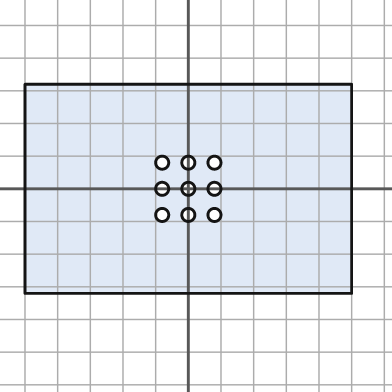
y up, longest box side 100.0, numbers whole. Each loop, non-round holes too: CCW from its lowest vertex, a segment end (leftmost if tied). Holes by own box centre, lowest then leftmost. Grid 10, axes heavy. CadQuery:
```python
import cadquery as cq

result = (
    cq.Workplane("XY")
    .moveTo(-50.0, -32.0)
    .lineTo(50.0, -32.0)
    .lineTo(50.0, 32.0)
    .lineTo(-50.0, 32.0)
    .close()
    .moveTo(-8.0, -8.0)
    .circle(2.0)
    .moveTo(0.0, -8.0)
    .circle(2.0)
    .moveTo(8.0, -8.0)
    .circle(2.0)
    .moveTo(-8.0, 0.0)
    .circle(2.0)
    .moveTo(0.0, 0.0)
    .circle(2.0)
    .moveTo(8.0, 0.0)
    .circle(2.0)
    .moveTo(-8.0, 8.0)
    .circle(2.0)
    .moveTo(0.0, 8.0)
    .circle(2.0)
    .moveTo(8.0, 8.0)
    .circle(2.0)
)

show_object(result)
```